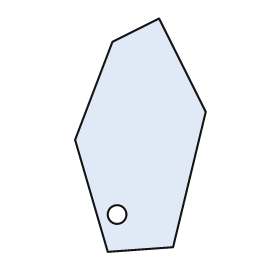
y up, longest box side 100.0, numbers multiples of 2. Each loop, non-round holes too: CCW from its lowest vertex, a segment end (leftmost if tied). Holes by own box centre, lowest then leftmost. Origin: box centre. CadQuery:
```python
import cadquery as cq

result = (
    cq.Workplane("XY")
    .moveTo(-14.0, -50.0)
    .lineTo(14.0, -48.0)
    .lineTo(28.0, 10.0)
    .lineTo(8.0, 50.0)
    .lineTo(-12.0, 40.0)
    .lineTo(-28.0, -2.0)
    .close()
    .moveTo(-10.0, -34.0)
    .circle(4.0)
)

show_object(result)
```